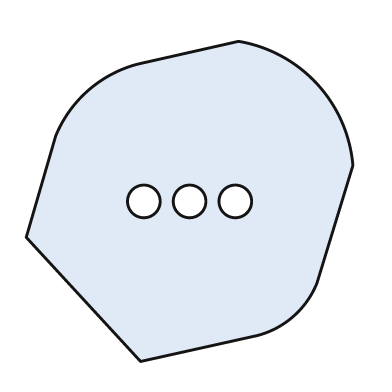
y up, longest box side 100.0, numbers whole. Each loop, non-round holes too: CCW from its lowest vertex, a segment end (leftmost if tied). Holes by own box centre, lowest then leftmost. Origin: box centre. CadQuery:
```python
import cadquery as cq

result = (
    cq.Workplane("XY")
    .moveTo(-15.0, -49.0)
    .lineTo(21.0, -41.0)
    .threePointArc((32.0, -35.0), (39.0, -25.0))
    .lineTo(50.0, 11.0)
    .threePointArc((39.0, 36.0), (15.0, 49.0))
    .lineTo(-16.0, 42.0)
    .threePointArc((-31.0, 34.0), (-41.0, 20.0))
    .lineTo(-50.0, -11.0)
    .close()
    .moveTo(-14.0, 0.0)
    .circle(5.0)
    .moveTo(0.0, 0.0)
    .circle(5.0)
    .moveTo(14.0, 0.0)
    .circle(5.0)
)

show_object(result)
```